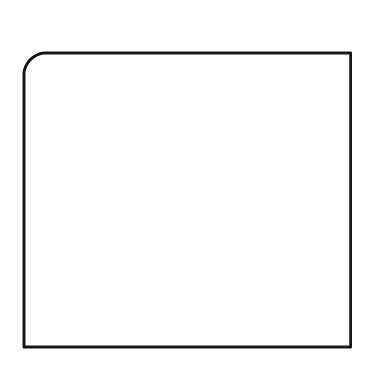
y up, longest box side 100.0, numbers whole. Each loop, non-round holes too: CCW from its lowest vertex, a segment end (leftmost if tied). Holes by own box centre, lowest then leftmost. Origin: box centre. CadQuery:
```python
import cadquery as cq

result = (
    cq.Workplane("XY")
    .moveTo(-50.0, -45.0)
    .lineTo(50.0, -45.0)
    .lineTo(50.0, 45.0)
    .lineTo(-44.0, 45.0)
    .threePointArc((-48.0, 43.0), (-50.0, 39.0))
    .close()
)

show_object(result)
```